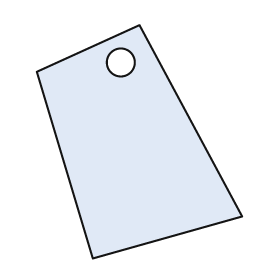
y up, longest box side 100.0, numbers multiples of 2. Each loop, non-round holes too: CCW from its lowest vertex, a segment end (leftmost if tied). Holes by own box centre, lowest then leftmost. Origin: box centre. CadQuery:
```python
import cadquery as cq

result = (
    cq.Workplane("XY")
    .moveTo(-20.0, -50.0)
    .lineTo(44.0, -32.0)
    .lineTo(0.0, 50.0)
    .lineTo(-44.0, 30.0)
    .close()
    .moveTo(-8.0, 34.0)
    .circle(6.0)
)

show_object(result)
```